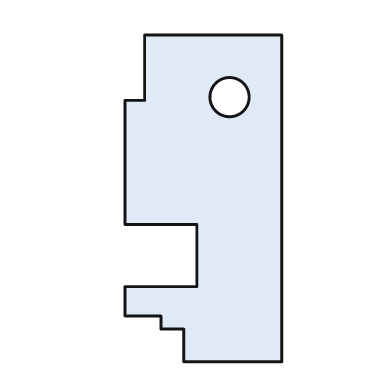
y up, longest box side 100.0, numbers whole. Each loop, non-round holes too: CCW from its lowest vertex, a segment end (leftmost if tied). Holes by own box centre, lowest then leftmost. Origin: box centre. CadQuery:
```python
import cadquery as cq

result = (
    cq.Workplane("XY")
    .moveTo(-6.0, -50.0)
    .lineTo(24.0, -50.0)
    .lineTo(24.0, 50.0)
    .lineTo(-18.0, 50.0)
    .lineTo(-18.0, 30.0)
    .lineTo(-24.0, 30.0)
    .lineTo(-24.0, -8.0)
    .lineTo(-2.0, -8.0)
    .lineTo(-2.0, -27.0)
    .lineTo(-24.0, -27.0)
    .lineTo(-24.0, -36.0)
    .lineTo(-13.0, -36.0)
    .lineTo(-13.0, -40.0)
    .lineTo(-6.0, -40.0)
    .close()
    .moveTo(8.0, 31.0)
    .circle(6.0)
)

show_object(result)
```